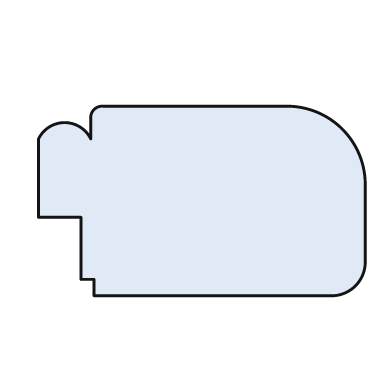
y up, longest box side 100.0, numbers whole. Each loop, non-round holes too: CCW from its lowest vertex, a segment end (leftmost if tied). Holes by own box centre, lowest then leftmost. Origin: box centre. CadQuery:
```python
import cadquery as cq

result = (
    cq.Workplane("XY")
    .moveTo(-33.0, -29.0)
    .lineTo(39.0, -29.0)
    .threePointArc((47.0, -26.0), (50.0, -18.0))
    .lineTo(50.0, 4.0)
    .threePointArc((43.0, 22.0), (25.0, 29.0))
    .lineTo(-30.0, 29.0)
    .threePointArc((-33.0, 28.0), (-34.0, 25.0))
    .lineTo(-34.0, 19.0)
    .threePointArc((-42.0, 24.0), (-50.0, 19.0))
    .lineTo(-50.0, -5.0)
    .lineTo(-37.0, -5.0)
    .lineTo(-37.0, -24.0)
    .lineTo(-33.0, -24.0)
    .close()
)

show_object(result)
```